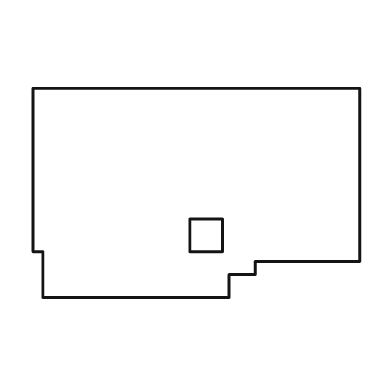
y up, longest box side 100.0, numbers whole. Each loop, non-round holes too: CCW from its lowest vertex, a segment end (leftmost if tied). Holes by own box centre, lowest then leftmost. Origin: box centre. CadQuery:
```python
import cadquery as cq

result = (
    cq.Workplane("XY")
    .moveTo(-47.0, -32.0)
    .lineTo(10.0, -32.0)
    .lineTo(10.0, -25.0)
    .lineTo(18.0, -25.0)
    .lineTo(18.0, -21.0)
    .lineTo(50.0, -21.0)
    .lineTo(50.0, 32.0)
    .lineTo(-50.0, 32.0)
    .lineTo(-50.0, -18.0)
    .lineTo(-47.0, -18.0)
    .close()
    .moveTo(-2.0, -18.0)
    .lineTo(8.0, -18.0)
    .lineTo(8.0, -8.0)
    .lineTo(-2.0, -8.0)
    .close()
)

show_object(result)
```